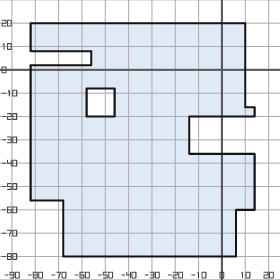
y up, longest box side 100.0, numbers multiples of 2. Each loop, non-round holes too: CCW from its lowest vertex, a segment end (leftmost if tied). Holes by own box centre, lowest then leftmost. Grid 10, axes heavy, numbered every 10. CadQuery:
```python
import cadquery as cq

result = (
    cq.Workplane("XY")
    .moveTo(-68.0, -80.0)
    .lineTo(6.0, -80.0)
    .lineTo(6.0, -60.0)
    .lineTo(14.0, -60.0)
    .lineTo(14.0, -36.0)
    .lineTo(-14.0, -36.0)
    .lineTo(-14.0, -20.0)
    .lineTo(14.0, -20.0)
    .lineTo(14.0, -16.0)
    .lineTo(10.0, -16.0)
    .lineTo(10.0, 20.0)
    .lineTo(-82.0, 20.0)
    .lineTo(-82.0, 8.0)
    .lineTo(-56.0, 8.0)
    .lineTo(-56.0, 2.0)
    .lineTo(-82.0, 2.0)
    .lineTo(-82.0, -56.0)
    .lineTo(-68.0, -56.0)
    .close()
    .moveTo(-58.0, -20.0)
    .lineTo(-46.0, -20.0)
    .lineTo(-46.0, -8.0)
    .lineTo(-58.0, -8.0)
    .close()
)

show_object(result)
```